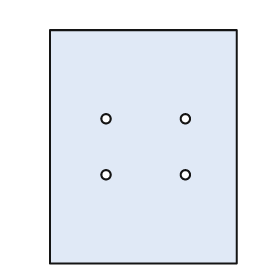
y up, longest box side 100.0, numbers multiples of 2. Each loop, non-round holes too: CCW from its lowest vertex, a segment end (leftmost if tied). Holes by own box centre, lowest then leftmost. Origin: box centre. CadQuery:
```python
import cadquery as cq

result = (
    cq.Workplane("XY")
    .moveTo(-40.0, -50.0)
    .lineTo(40.0, -50.0)
    .lineTo(40.0, 50.0)
    .lineTo(-40.0, 50.0)
    .close()
    .moveTo(-16.0, -12.0)
    .circle(2.0)
    .moveTo(18.0, -12.0)
    .circle(2.0)
    .moveTo(-16.0, 12.0)
    .circle(2.0)
    .moveTo(18.0, 12.0)
    .circle(2.0)
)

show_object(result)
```